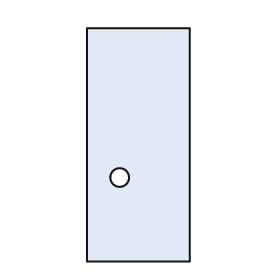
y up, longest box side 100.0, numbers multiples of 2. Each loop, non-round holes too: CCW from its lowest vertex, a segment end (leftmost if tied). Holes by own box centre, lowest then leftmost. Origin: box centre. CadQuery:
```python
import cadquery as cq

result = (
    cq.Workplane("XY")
    .moveTo(-22.0, -50.0)
    .lineTo(22.0, -50.0)
    .lineTo(22.0, 50.0)
    .lineTo(-22.0, 50.0)
    .close()
    .moveTo(-8.0, -14.0)
    .circle(4.0)
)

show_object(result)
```